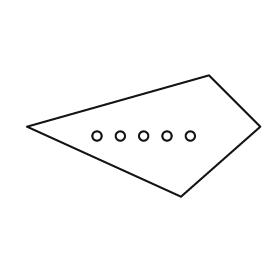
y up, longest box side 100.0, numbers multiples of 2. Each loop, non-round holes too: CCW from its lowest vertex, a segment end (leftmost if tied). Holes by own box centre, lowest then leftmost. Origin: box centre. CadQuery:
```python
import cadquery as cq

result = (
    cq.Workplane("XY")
    .moveTo(16.0, -26.0)
    .lineTo(50.0, 4.0)
    .lineTo(28.0, 26.0)
    .lineTo(-50.0, 4.0)
    .close()
    .moveTo(-20.0, 0.0)
    .circle(2.0)
    .moveTo(-10.0, 0.0)
    .circle(2.0)
    .moveTo(0.0, 0.0)
    .circle(2.0)
    .moveTo(10.0, 0.0)
    .circle(2.0)
    .moveTo(20.0, 0.0)
    .circle(2.0)
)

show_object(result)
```